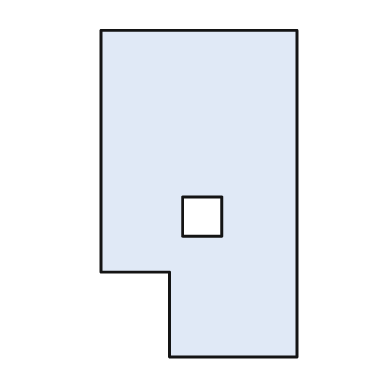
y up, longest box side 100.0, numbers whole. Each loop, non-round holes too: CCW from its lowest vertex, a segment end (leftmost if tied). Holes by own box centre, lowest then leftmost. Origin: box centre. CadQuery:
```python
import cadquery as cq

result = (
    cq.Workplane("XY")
    .moveTo(-9.0, -50.0)
    .lineTo(30.0, -50.0)
    .lineTo(30.0, 50.0)
    .lineTo(-30.0, 50.0)
    .lineTo(-30.0, -24.0)
    .lineTo(-9.0, -24.0)
    .close()
    .moveTo(-5.0, -13.0)
    .lineTo(7.0, -13.0)
    .lineTo(7.0, -1.0)
    .lineTo(-5.0, -1.0)
    .close()
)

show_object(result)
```